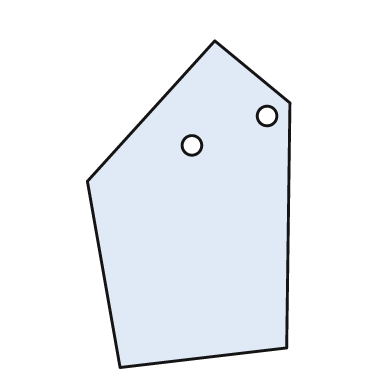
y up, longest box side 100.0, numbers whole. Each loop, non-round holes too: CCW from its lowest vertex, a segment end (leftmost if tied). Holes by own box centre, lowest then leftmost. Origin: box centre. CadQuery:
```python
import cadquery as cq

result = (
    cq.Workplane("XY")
    .moveTo(-21.0, -50.0)
    .lineTo(30.0, -44.0)
    .lineTo(31.0, 31.0)
    .lineTo(8.0, 50.0)
    .lineTo(-31.0, 7.0)
    .close()
    .moveTo(1.0, 18.0)
    .circle(3.0)
    .moveTo(24.0, 27.0)
    .circle(3.0)
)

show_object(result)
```